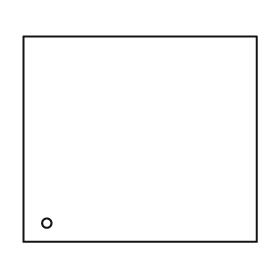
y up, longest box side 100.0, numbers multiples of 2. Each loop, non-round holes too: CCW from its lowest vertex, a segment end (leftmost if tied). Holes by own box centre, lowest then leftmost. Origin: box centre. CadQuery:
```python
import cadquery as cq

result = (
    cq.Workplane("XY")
    .moveTo(-50.0, -44.0)
    .lineTo(50.0, -44.0)
    .lineTo(50.0, 44.0)
    .lineTo(-50.0, 44.0)
    .close()
    .moveTo(-40.0, -36.0)
    .circle(2.0)
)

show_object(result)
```